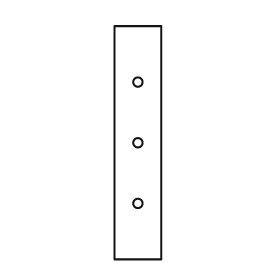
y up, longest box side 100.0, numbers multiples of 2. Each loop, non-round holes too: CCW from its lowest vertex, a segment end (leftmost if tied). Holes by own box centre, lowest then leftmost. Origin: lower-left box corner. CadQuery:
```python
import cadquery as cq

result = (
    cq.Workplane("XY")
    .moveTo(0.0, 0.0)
    .lineTo(20.0, 0.0)
    .lineTo(20.0, 100.0)
    .lineTo(0.0, 100.0)
    .close()
    .moveTo(10.0, 24.0)
    .circle(2.0)
    .moveTo(10.0, 50.0)
    .circle(2.0)
    .moveTo(10.0, 76.0)
    .circle(2.0)
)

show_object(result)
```